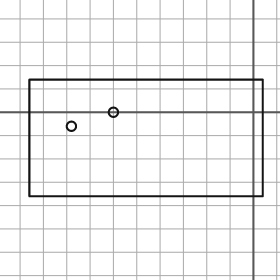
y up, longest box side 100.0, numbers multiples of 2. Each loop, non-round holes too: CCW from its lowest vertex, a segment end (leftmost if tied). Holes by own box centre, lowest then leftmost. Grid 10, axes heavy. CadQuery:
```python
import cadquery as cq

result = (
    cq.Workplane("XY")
    .moveTo(-96.0, -36.0)
    .lineTo(4.0, -36.0)
    .lineTo(4.0, 14.0)
    .lineTo(-96.0, 14.0)
    .close()
    .moveTo(-78.0, -6.0)
    .circle(2.0)
    .moveTo(-60.0, 0.0)
    .circle(2.0)
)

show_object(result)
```